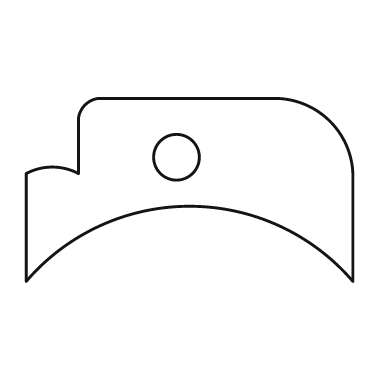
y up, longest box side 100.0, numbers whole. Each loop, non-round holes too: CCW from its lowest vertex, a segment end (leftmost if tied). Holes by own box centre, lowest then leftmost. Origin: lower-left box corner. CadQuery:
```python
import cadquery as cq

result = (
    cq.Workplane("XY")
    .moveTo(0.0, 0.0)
    .threePointArc((50.0, 23.0), (100.0, 0.0))
    .lineTo(100.0, 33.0)
    .threePointArc((93.0, 49.0), (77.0, 56.0))
    .lineTo(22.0, 56.0)
    .threePointArc((18.0, 54.0), (16.0, 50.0))
    .lineTo(16.0, 33.0)
    .threePointArc((8.0, 35.0), (0.0, 33.0))
    .close()
    .moveTo(46.0, 38.0)
    .circle(7.0)
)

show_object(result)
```